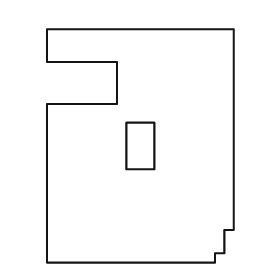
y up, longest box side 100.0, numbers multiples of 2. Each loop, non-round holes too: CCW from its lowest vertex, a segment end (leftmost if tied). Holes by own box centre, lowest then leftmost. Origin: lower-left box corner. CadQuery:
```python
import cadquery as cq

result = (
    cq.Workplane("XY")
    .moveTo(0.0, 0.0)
    .lineTo(72.0, 0.0)
    .lineTo(72.0, 4.0)
    .lineTo(76.0, 4.0)
    .lineTo(76.0, 14.0)
    .lineTo(80.0, 14.0)
    .lineTo(80.0, 100.0)
    .lineTo(0.0, 100.0)
    .lineTo(0.0, 86.0)
    .lineTo(30.0, 86.0)
    .lineTo(30.0, 68.0)
    .lineTo(0.0, 68.0)
    .close()
    .moveTo(34.0, 40.0)
    .lineTo(46.0, 40.0)
    .lineTo(46.0, 60.0)
    .lineTo(34.0, 60.0)
    .close()
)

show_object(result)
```